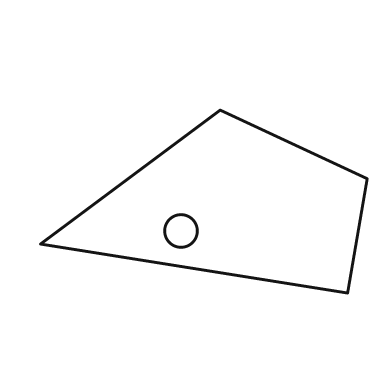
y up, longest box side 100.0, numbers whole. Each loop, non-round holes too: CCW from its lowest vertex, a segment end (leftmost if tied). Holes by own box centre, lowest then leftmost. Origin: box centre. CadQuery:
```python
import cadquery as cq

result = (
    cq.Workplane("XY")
    .moveTo(44.0, -28.0)
    .lineTo(50.0, 7.0)
    .lineTo(5.0, 28.0)
    .lineTo(-50.0, -13.0)
    .close()
    .moveTo(-7.0, -9.0)
    .circle(5.0)
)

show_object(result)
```